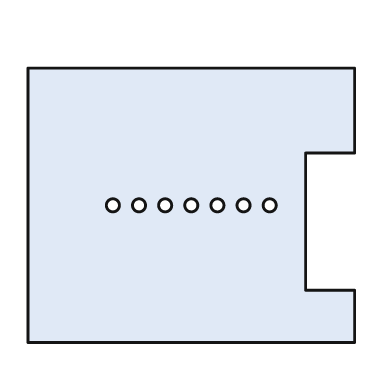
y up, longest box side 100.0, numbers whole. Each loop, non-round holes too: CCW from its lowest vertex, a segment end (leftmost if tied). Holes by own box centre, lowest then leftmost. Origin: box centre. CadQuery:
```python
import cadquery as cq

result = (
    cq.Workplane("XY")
    .moveTo(-50.0, -42.0)
    .lineTo(50.0, -42.0)
    .lineTo(50.0, -26.0)
    .lineTo(35.0, -26.0)
    .lineTo(35.0, 16.0)
    .lineTo(50.0, 16.0)
    .lineTo(50.0, 42.0)
    .lineTo(-50.0, 42.0)
    .close()
    .moveTo(-24.0, 0.0)
    .circle(2.0)
    .moveTo(-16.0, 0.0)
    .circle(2.0)
    .moveTo(-8.0, 0.0)
    .circle(2.0)
    .moveTo(0.0, 0.0)
    .circle(2.0)
    .moveTo(8.0, 0.0)
    .circle(2.0)
    .moveTo(16.0, 0.0)
    .circle(2.0)
    .moveTo(24.0, 0.0)
    .circle(2.0)
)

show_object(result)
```